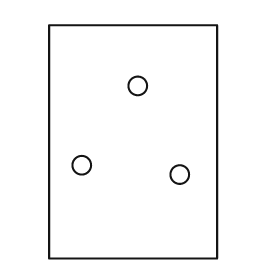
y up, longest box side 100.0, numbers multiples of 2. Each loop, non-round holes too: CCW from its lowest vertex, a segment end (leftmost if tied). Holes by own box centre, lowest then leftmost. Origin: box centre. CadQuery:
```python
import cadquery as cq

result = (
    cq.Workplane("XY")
    .moveTo(-36.0, -50.0)
    .lineTo(36.0, -50.0)
    .lineTo(36.0, 50.0)
    .lineTo(-36.0, 50.0)
    .close()
    .moveTo(20.0, -14.0)
    .circle(4.0)
    .moveTo(-22.0, -10.0)
    .circle(4.0)
    .moveTo(2.0, 24.0)
    .circle(4.0)
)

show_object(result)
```